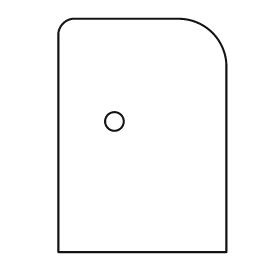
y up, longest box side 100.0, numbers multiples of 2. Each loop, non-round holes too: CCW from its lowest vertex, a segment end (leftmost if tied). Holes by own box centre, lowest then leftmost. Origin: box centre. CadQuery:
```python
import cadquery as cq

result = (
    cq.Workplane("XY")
    .moveTo(-36.0, -50.0)
    .lineTo(36.0, -50.0)
    .lineTo(36.0, 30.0)
    .threePointArc((30.0, 44.0), (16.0, 50.0))
    .lineTo(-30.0, 50.0)
    .threePointArc((-34.0, 48.0), (-36.0, 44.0))
    .close()
    .moveTo(-12.0, 6.0)
    .circle(4.0)
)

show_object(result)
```